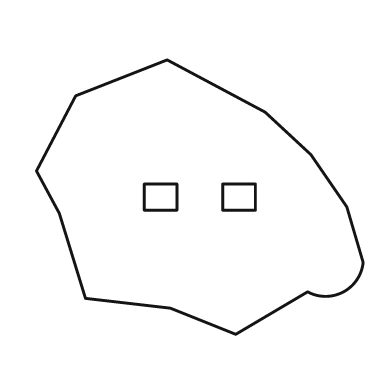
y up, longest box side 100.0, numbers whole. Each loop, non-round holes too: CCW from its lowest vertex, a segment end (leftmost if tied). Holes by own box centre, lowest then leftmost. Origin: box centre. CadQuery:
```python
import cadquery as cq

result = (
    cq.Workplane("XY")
    .moveTo(11.0, -42.0)
    .lineTo(33.0, -29.0)
    .threePointArc((44.0, -29.0), (50.0, -20.0))
    .lineTo(45.0, -3.0)
    .lineTo(34.0, 13.0)
    .lineTo(20.0, 26.0)
    .lineTo(-10.0, 42.0)
    .lineTo(-38.0, 31.0)
    .lineTo(-50.0, 8.0)
    .lineTo(-43.0, -5.0)
    .lineTo(-35.0, -31.0)
    .lineTo(-9.0, -34.0)
    .close()
    .moveTo(-17.0, -4.0)
    .lineTo(-7.0, -4.0)
    .lineTo(-7.0, 4.0)
    .lineTo(-17.0, 4.0)
    .close()
    .moveTo(7.0, -4.0)
    .lineTo(17.0, -4.0)
    .lineTo(17.0, 4.0)
    .lineTo(7.0, 4.0)
    .close()
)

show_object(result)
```